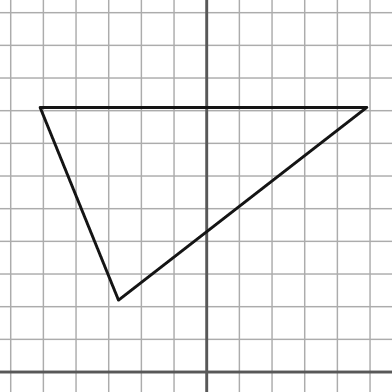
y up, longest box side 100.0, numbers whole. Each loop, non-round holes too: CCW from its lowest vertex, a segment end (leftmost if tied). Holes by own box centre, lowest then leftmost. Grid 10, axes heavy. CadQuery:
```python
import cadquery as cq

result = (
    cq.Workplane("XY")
    .moveTo(-27.0, 22.0)
    .lineTo(49.0, 81.0)
    .lineTo(-51.0, 81.0)
    .close()
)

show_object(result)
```